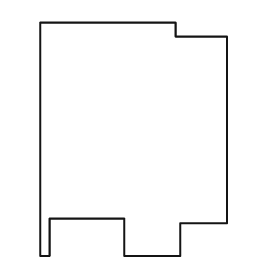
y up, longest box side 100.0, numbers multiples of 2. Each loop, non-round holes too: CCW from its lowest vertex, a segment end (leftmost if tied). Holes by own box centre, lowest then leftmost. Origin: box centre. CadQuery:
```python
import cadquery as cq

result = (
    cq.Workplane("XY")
    .moveTo(-40.0, -50.0)
    .lineTo(-36.0, -50.0)
    .lineTo(-36.0, -34.0)
    .lineTo(-4.0, -34.0)
    .lineTo(-4.0, -50.0)
    .lineTo(20.0, -50.0)
    .lineTo(20.0, -36.0)
    .lineTo(40.0, -36.0)
    .lineTo(40.0, 44.0)
    .lineTo(18.0, 44.0)
    .lineTo(18.0, 50.0)
    .lineTo(-40.0, 50.0)
    .close()
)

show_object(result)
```